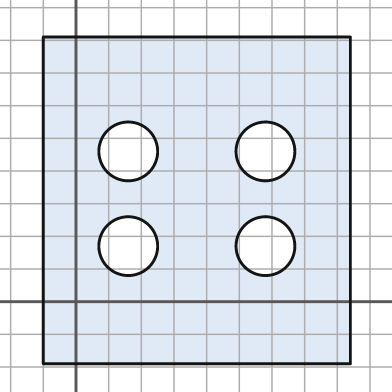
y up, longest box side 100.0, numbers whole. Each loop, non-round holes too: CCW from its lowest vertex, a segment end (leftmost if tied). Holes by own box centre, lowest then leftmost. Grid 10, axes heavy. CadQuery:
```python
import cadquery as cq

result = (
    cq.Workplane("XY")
    .moveTo(-10.0, -19.0)
    .lineTo(84.0, -19.0)
    .lineTo(84.0, 81.0)
    .lineTo(-10.0, 81.0)
    .close()
    .moveTo(16.0, 17.0)
    .circle(9.0)
    .moveTo(58.0, 17.0)
    .circle(9.0)
    .moveTo(16.0, 46.0)
    .circle(9.0)
    .moveTo(58.0, 46.0)
    .circle(9.0)
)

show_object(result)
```